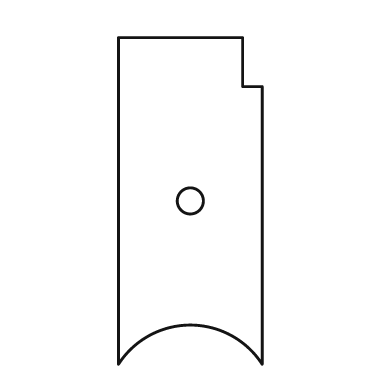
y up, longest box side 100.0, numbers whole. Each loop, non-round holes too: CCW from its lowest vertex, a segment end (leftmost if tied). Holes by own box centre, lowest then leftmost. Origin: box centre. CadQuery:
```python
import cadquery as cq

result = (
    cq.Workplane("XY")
    .moveTo(-22.0, -50.0)
    .threePointArc((0.0, -38.0), (22.0, -50.0))
    .lineTo(22.0, 35.0)
    .lineTo(16.0, 35.0)
    .lineTo(16.0, 50.0)
    .lineTo(-22.0, 50.0)
    .close()
    .moveTo(0.0, 0.0)
    .circle(4.0)
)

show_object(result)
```